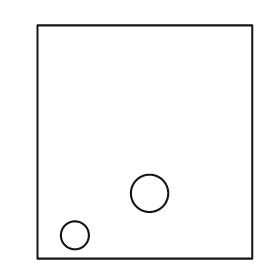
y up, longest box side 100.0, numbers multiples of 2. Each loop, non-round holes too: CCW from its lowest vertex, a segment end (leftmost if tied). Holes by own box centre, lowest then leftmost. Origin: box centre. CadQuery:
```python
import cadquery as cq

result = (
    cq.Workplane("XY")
    .moveTo(-46.0, -50.0)
    .lineTo(46.0, -50.0)
    .lineTo(46.0, 50.0)
    .lineTo(-46.0, 50.0)
    .close()
    .moveTo(-30.0, -40.0)
    .circle(6.0)
    .moveTo(2.0, -22.0)
    .circle(8.0)
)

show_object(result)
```